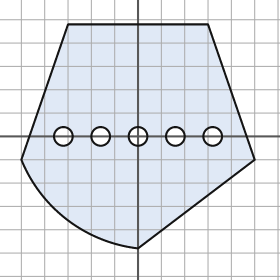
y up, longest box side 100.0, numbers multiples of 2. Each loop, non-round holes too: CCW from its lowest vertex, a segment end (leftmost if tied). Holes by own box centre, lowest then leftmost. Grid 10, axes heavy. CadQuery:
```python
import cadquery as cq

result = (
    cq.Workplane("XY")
    .moveTo(0.0, -48.0)
    .lineTo(50.0, -10.0)
    .lineTo(30.0, 48.0)
    .lineTo(-30.0, 48.0)
    .lineTo(-50.0, -10.0)
    .threePointArc((-30.0, -36.0), (0.0, -48.0))
    .close()
    .moveTo(-32.0, 0.0)
    .circle(4.0)
    .moveTo(-16.0, 0.0)
    .circle(4.0)
    .moveTo(0.0, 0.0)
    .circle(4.0)
    .moveTo(16.0, 0.0)
    .circle(4.0)
    .moveTo(32.0, 0.0)
    .circle(4.0)
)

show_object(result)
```